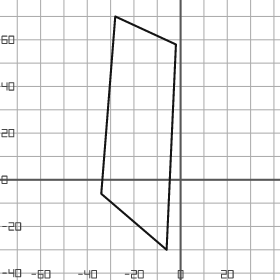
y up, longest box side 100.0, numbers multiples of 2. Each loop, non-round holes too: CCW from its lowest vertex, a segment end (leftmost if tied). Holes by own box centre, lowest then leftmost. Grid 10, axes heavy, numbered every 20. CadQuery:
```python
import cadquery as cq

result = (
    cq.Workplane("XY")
    .moveTo(-6.0, -30.0)
    .lineTo(-2.0, 58.0)
    .lineTo(-28.0, 70.0)
    .lineTo(-34.0, -6.0)
    .close()
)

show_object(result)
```